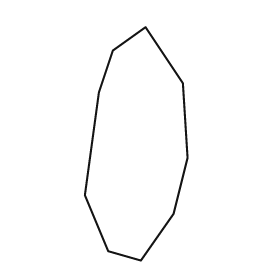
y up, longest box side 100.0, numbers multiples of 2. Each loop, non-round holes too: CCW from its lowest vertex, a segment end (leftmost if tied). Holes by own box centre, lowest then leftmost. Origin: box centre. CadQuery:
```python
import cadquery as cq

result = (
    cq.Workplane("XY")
    .moveTo(2.0, -50.0)
    .lineTo(16.0, -30.0)
    .lineTo(22.0, -6.0)
    .lineTo(20.0, 26.0)
    .lineTo(4.0, 50.0)
    .lineTo(-10.0, 40.0)
    .lineTo(-16.0, 22.0)
    .lineTo(-22.0, -22.0)
    .lineTo(-12.0, -46.0)
    .close()
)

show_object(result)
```